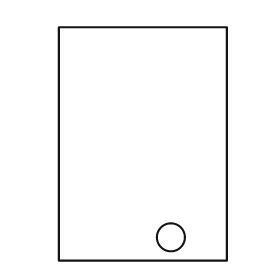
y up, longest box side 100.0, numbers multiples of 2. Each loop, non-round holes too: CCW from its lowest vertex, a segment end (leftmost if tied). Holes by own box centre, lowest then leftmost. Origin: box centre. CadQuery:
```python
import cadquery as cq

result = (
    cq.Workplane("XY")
    .moveTo(-36.0, -50.0)
    .lineTo(36.0, -50.0)
    .lineTo(36.0, 50.0)
    .lineTo(-36.0, 50.0)
    .close()
    .moveTo(12.0, -40.0)
    .circle(6.0)
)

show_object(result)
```